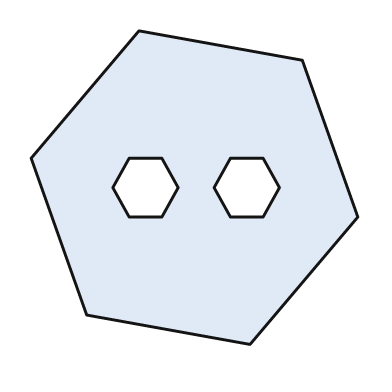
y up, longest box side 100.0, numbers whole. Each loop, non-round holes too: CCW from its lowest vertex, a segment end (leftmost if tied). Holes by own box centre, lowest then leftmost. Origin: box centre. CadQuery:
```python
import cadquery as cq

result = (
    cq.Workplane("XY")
    .moveTo(17.0, -48.0)
    .lineTo(50.0, -9.0)
    .lineTo(33.0, 39.0)
    .lineTo(-17.0, 48.0)
    .lineTo(-50.0, 9.0)
    .lineTo(-33.0, -39.0)
    .close()
    .moveTo(-20.0, -9.0)
    .lineTo(-10.0, -9.0)
    .lineTo(-5.0, 0.0)
    .lineTo(-10.0, 9.0)
    .lineTo(-20.0, 9.0)
    .lineTo(-25.0, 0.0)
    .close()
    .moveTo(11.0, -9.0)
    .lineTo(21.0, -9.0)
    .lineTo(26.0, 0.0)
    .lineTo(21.0, 9.0)
    .lineTo(11.0, 9.0)
    .lineTo(6.0, 0.0)
    .close()
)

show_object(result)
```